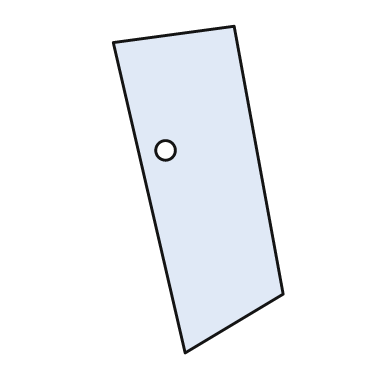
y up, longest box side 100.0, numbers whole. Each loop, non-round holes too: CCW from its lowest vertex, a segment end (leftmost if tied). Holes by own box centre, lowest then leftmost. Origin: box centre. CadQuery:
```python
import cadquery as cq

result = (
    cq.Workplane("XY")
    .moveTo(-4.0, -50.0)
    .lineTo(26.0, -32.0)
    .lineTo(11.0, 50.0)
    .lineTo(-26.0, 45.0)
    .close()
    .moveTo(-10.0, 12.0)
    .circle(3.0)
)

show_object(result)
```